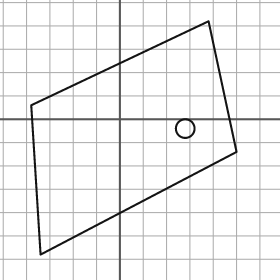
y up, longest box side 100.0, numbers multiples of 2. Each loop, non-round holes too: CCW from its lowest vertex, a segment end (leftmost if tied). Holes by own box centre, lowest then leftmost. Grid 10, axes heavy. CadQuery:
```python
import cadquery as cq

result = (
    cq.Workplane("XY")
    .moveTo(-34.0, -58.0)
    .lineTo(50.0, -14.0)
    .lineTo(38.0, 42.0)
    .lineTo(-38.0, 6.0)
    .close()
    .moveTo(28.0, -4.0)
    .circle(4.0)
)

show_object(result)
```